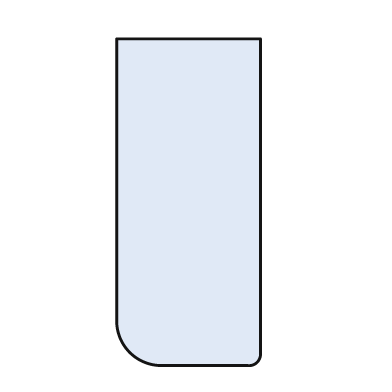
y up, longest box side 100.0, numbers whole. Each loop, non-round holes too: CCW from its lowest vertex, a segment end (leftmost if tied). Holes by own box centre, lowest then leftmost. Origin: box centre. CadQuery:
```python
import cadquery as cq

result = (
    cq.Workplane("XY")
    .moveTo(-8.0, -50.0)
    .lineTo(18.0, -50.0)
    .threePointArc((21.0, -49.0), (22.0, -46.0))
    .lineTo(22.0, 50.0)
    .lineTo(-22.0, 50.0)
    .lineTo(-22.0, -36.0)
    .threePointArc((-18.0, -46.0), (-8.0, -50.0))
    .close()
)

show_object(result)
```